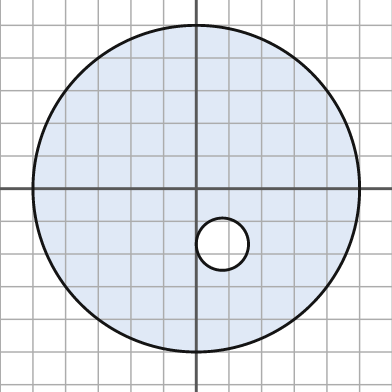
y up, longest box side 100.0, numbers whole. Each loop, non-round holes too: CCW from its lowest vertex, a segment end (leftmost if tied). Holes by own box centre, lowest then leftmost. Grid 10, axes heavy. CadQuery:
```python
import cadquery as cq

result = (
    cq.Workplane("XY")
    .moveTo(0.0, 0.0)
    .circle(50.0)
    .moveTo(8.0, -17.0)
    .circle(8.0)
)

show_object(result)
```